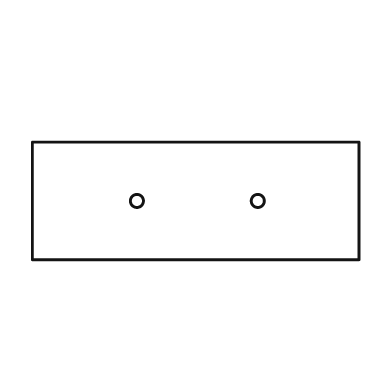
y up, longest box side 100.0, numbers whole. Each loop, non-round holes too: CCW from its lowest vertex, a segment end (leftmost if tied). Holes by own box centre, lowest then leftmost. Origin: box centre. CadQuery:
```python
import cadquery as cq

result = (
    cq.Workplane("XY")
    .moveTo(-50.0, -18.0)
    .lineTo(50.0, -18.0)
    .lineTo(50.0, 18.0)
    .lineTo(-50.0, 18.0)
    .close()
    .moveTo(-18.0, 0.0)
    .circle(2.0)
    .moveTo(19.0, 0.0)
    .circle(2.0)
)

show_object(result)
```